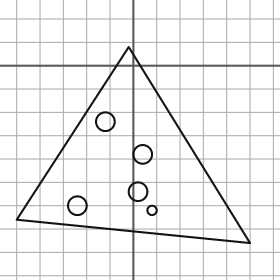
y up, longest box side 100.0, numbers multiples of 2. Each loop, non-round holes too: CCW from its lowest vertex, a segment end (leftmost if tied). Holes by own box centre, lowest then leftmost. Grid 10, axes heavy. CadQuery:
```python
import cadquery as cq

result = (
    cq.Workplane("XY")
    .moveTo(50.0, -76.0)
    .lineTo(-2.0, 8.0)
    .lineTo(-50.0, -66.0)
    .close()
    .moveTo(8.0, -62.0)
    .circle(2.0)
    .moveTo(-24.0, -60.0)
    .circle(4.0)
    .moveTo(2.0, -54.0)
    .circle(4.0)
    .moveTo(4.0, -38.0)
    .circle(4.0)
    .moveTo(-12.0, -24.0)
    .circle(4.0)
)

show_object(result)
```